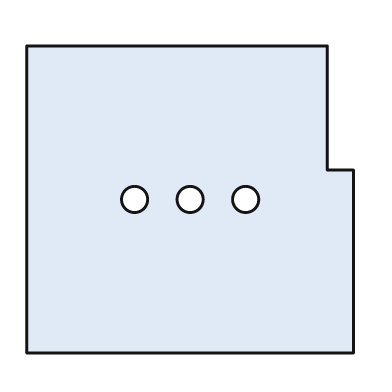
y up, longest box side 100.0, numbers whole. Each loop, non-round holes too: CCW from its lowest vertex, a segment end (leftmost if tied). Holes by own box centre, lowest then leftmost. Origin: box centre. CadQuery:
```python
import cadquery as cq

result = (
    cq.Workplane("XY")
    .moveTo(-50.0, -47.0)
    .lineTo(50.0, -47.0)
    .lineTo(50.0, 9.0)
    .lineTo(42.0, 9.0)
    .lineTo(42.0, 47.0)
    .lineTo(-50.0, 47.0)
    .close()
    .moveTo(-17.0, 0.0)
    .circle(4.0)
    .moveTo(0.0, 0.0)
    .circle(4.0)
    .moveTo(17.0, 0.0)
    .circle(4.0)
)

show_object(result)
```